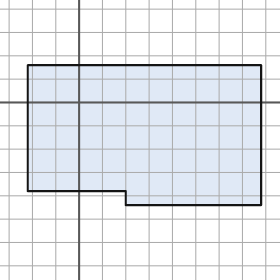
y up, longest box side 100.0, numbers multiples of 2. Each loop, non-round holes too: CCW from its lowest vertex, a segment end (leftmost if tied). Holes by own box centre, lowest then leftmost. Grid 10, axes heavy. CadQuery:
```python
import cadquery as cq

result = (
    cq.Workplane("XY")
    .moveTo(20.0, -44.0)
    .lineTo(78.0, -44.0)
    .lineTo(78.0, 16.0)
    .lineTo(-22.0, 16.0)
    .lineTo(-22.0, -38.0)
    .lineTo(20.0, -38.0)
    .close()
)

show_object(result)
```